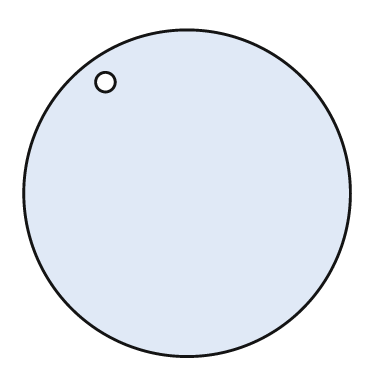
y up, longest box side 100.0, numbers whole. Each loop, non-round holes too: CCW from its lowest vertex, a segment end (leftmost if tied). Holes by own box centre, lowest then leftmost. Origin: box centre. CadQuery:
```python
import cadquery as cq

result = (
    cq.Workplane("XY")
    .moveTo(0.0, 0.0)
    .circle(50.0)
    .moveTo(-25.0, 34.0)
    .circle(3.0)
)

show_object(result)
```